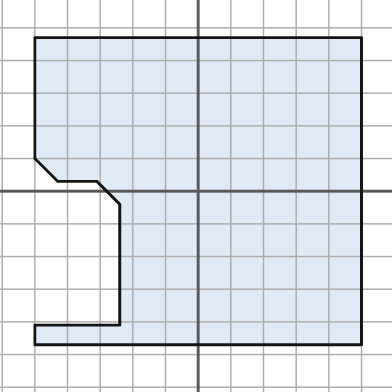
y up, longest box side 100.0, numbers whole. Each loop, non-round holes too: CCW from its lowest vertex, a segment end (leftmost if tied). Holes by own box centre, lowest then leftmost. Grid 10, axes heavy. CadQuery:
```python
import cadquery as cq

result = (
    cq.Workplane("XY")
    .moveTo(-50.0, -47.0)
    .lineTo(50.0, -47.0)
    .lineTo(50.0, 47.0)
    .lineTo(-50.0, 47.0)
    .lineTo(-50.0, 10.0)
    .lineTo(-43.0, 3.0)
    .lineTo(-31.0, 3.0)
    .lineTo(-24.0, -4.0)
    .lineTo(-24.0, -41.0)
    .lineTo(-50.0, -41.0)
    .close()
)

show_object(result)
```